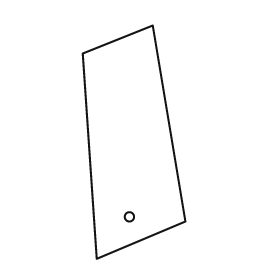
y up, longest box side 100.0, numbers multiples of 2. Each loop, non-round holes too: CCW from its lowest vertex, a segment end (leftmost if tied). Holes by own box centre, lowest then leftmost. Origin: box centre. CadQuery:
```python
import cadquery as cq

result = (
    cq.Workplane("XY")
    .moveTo(-16.0, -50.0)
    .lineTo(22.0, -34.0)
    .lineTo(8.0, 50.0)
    .lineTo(-22.0, 38.0)
    .close()
    .moveTo(-2.0, -32.0)
    .circle(2.0)
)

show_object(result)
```